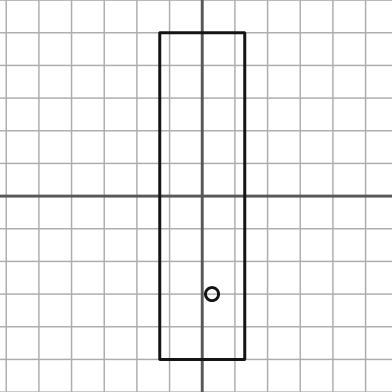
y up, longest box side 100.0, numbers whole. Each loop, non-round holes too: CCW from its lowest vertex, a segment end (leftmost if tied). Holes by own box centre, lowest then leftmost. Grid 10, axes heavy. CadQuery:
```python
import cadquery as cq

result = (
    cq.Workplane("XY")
    .moveTo(-13.0, -50.0)
    .lineTo(13.0, -50.0)
    .lineTo(13.0, 50.0)
    .lineTo(-13.0, 50.0)
    .close()
    .moveTo(3.0, -30.0)
    .circle(2.0)
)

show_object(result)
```